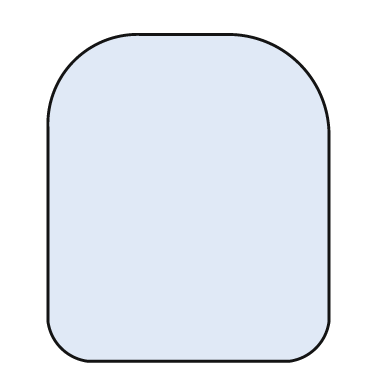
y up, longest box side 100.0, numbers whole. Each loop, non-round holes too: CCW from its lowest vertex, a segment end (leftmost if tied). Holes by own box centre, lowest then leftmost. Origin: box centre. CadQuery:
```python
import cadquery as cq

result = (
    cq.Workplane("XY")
    .moveTo(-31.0, -50.0)
    .lineTo(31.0, -50.0)
    .threePointArc((39.0, -46.0), (43.0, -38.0))
    .lineTo(43.0, 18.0)
    .threePointArc((34.0, 41.0), (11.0, 50.0))
    .lineTo(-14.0, 50.0)
    .threePointArc((-35.0, 42.0), (-43.0, 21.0))
    .lineTo(-43.0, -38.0)
    .threePointArc((-39.0, -46.0), (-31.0, -50.0))
    .close()
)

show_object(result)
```